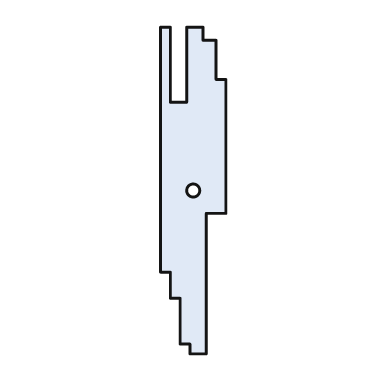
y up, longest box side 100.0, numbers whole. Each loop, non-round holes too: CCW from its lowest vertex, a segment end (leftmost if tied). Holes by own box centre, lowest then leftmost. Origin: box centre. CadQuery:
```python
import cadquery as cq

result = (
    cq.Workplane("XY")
    .moveTo(-1.0, -50.0)
    .lineTo(4.0, -50.0)
    .lineTo(4.0, -7.0)
    .lineTo(10.0, -7.0)
    .lineTo(10.0, 34.0)
    .lineTo(7.0, 34.0)
    .lineTo(7.0, 46.0)
    .lineTo(3.0, 46.0)
    .lineTo(3.0, 50.0)
    .lineTo(-2.0, 50.0)
    .lineTo(-2.0, 27.0)
    .lineTo(-7.0, 27.0)
    .lineTo(-7.0, 50.0)
    .lineTo(-10.0, 50.0)
    .lineTo(-10.0, -25.0)
    .lineTo(-7.0, -25.0)
    .lineTo(-7.0, -33.0)
    .lineTo(-4.0, -33.0)
    .lineTo(-4.0, -47.0)
    .lineTo(-1.0, -47.0)
    .close()
    .moveTo(0.0, 0.0)
    .circle(2.0)
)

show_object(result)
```